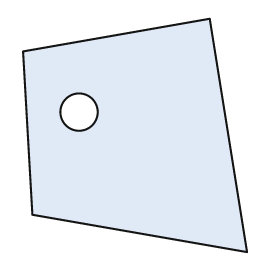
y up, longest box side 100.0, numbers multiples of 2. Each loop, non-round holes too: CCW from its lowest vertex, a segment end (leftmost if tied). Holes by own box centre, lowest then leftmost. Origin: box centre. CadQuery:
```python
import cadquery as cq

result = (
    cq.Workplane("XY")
    .moveTo(48.0, -50.0)
    .lineTo(32.0, 50.0)
    .lineTo(-48.0, 36.0)
    .lineTo(-44.0, -34.0)
    .close()
    .moveTo(-24.0, 10.0)
    .circle(8.0)
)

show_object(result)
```